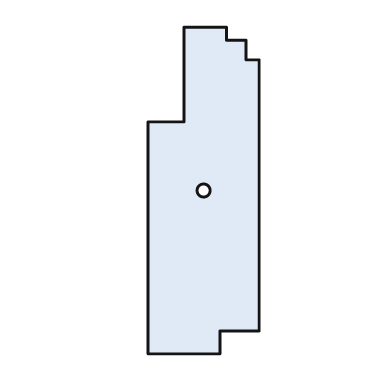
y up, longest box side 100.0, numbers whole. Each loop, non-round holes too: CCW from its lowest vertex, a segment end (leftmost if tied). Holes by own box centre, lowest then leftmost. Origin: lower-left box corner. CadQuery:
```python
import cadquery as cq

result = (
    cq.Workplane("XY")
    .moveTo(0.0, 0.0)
    .lineTo(22.0, 0.0)
    .lineTo(22.0, 7.0)
    .lineTo(34.0, 7.0)
    .lineTo(34.0, 90.0)
    .lineTo(30.0, 90.0)
    .lineTo(30.0, 96.0)
    .lineTo(24.0, 96.0)
    .lineTo(24.0, 100.0)
    .lineTo(11.0, 100.0)
    .lineTo(11.0, 71.0)
    .lineTo(0.0, 71.0)
    .close()
    .moveTo(17.0, 50.0)
    .circle(2.0)
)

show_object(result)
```